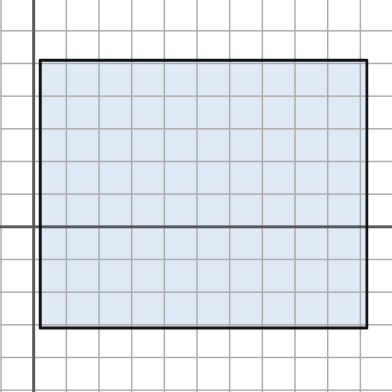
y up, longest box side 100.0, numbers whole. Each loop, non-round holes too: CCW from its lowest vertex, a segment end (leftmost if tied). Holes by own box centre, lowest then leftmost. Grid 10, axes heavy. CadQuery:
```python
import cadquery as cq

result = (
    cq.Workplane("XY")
    .moveTo(2.0, -31.0)
    .lineTo(102.0, -31.0)
    .lineTo(102.0, 51.0)
    .lineTo(2.0, 51.0)
    .close()
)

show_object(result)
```